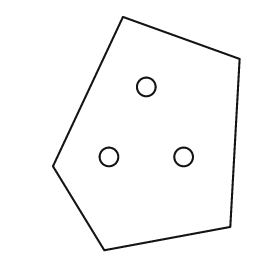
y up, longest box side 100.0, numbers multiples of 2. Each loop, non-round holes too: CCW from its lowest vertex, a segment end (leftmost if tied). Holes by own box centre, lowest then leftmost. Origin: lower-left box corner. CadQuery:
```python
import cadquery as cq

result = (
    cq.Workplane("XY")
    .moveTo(22.0, 0.0)
    .lineTo(76.0, 10.0)
    .lineTo(80.0, 82.0)
    .lineTo(30.0, 100.0)
    .lineTo(0.0, 36.0)
    .close()
    .moveTo(24.0, 40.0)
    .circle(4.0)
    .moveTo(56.0, 40.0)
    .circle(4.0)
    .moveTo(40.0, 70.0)
    .circle(4.0)
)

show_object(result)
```